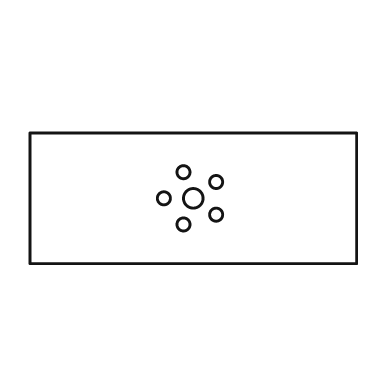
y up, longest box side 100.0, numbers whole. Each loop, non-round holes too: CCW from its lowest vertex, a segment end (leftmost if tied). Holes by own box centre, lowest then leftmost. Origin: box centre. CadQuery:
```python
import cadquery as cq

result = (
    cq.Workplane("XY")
    .moveTo(-50.0, -20.0)
    .lineTo(50.0, -20.0)
    .lineTo(50.0, 20.0)
    .lineTo(-50.0, 20.0)
    .close()
    .moveTo(-3.0, -8.0)
    .circle(2.0)
    .moveTo(7.0, -5.0)
    .circle(2.0)
    .moveTo(-9.0, 0.0)
    .circle(2.0)
    .moveTo(0.0, 0.0)
    .circle(3.0)
    .moveTo(7.0, 5.0)
    .circle(2.0)
    .moveTo(-3.0, 8.0)
    .circle(2.0)
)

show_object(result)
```